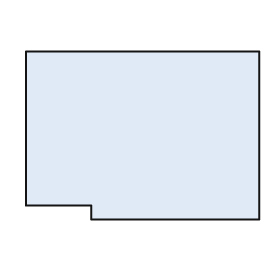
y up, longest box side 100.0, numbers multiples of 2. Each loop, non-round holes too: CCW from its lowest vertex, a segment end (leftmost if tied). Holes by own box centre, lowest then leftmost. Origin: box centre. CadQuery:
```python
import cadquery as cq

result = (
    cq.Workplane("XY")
    .moveTo(-22.0, -36.0)
    .lineTo(50.0, -36.0)
    .lineTo(50.0, 36.0)
    .lineTo(-50.0, 36.0)
    .lineTo(-50.0, -30.0)
    .lineTo(-22.0, -30.0)
    .close()
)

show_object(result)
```